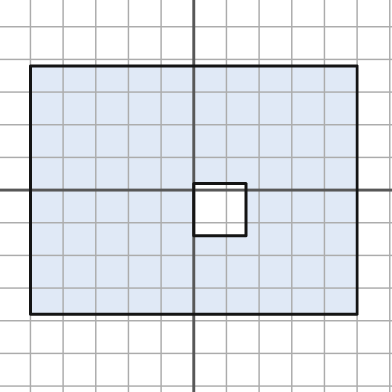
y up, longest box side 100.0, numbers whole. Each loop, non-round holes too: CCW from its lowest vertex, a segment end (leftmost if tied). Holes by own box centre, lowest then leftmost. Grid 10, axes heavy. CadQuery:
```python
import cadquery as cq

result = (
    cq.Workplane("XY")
    .moveTo(-50.0, -38.0)
    .lineTo(50.0, -38.0)
    .lineTo(50.0, 38.0)
    .lineTo(-50.0, 38.0)
    .close()
    .moveTo(0.0, -14.0)
    .lineTo(16.0, -14.0)
    .lineTo(16.0, 2.0)
    .lineTo(0.0, 2.0)
    .close()
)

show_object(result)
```